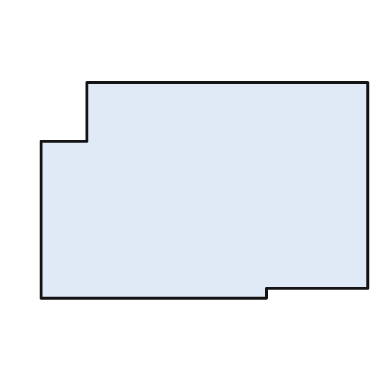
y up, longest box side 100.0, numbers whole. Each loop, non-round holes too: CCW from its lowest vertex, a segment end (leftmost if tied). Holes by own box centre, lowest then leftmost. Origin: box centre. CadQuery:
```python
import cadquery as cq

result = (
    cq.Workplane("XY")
    .moveTo(-50.0, -33.0)
    .lineTo(19.0, -33.0)
    .lineTo(19.0, -30.0)
    .lineTo(50.0, -30.0)
    .lineTo(50.0, 33.0)
    .lineTo(-36.0, 33.0)
    .lineTo(-36.0, 15.0)
    .lineTo(-50.0, 15.0)
    .close()
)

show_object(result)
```